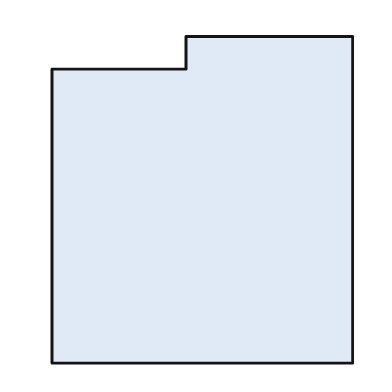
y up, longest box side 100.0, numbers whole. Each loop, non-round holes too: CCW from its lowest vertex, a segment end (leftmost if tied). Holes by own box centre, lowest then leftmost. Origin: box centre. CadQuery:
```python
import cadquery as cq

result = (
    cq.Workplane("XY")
    .moveTo(-46.0, -50.0)
    .lineTo(46.0, -50.0)
    .lineTo(46.0, 50.0)
    .lineTo(-5.0, 50.0)
    .lineTo(-5.0, 40.0)
    .lineTo(-46.0, 40.0)
    .close()
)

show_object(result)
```